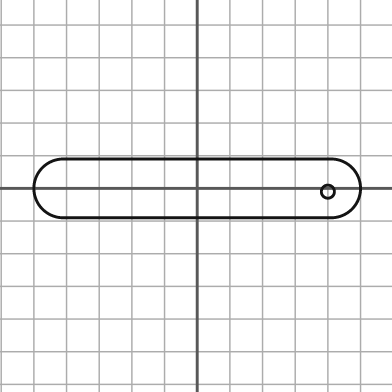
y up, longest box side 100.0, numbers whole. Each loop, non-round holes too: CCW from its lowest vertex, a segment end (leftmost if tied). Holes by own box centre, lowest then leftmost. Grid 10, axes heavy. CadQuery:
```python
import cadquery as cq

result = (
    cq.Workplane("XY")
    .moveTo(-41.0, -9.0)
    .lineTo(41.0, -9.0)
    .threePointArc((50.0, 0.0), (41.0, 9.0))
    .lineTo(-41.0, 9.0)
    .threePointArc((-50.0, 0.0), (-41.0, -9.0))
    .close()
    .moveTo(40.0, -1.0)
    .circle(2.0)
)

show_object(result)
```